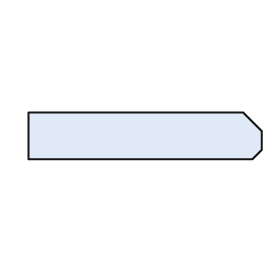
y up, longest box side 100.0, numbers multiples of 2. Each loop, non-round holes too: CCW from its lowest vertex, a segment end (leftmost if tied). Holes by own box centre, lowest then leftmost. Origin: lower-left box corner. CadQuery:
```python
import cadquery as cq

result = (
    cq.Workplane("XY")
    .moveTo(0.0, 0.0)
    .lineTo(96.0, 0.0)
    .lineTo(100.0, 4.0)
    .lineTo(100.0, 12.0)
    .lineTo(92.0, 20.0)
    .lineTo(0.0, 20.0)
    .close()
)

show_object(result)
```